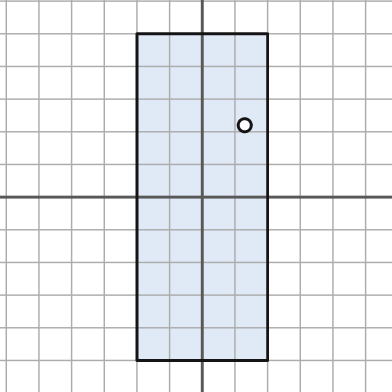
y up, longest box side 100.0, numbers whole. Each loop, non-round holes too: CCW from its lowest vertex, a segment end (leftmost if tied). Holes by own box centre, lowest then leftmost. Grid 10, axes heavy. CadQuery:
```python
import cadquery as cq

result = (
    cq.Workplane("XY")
    .moveTo(-20.0, -50.0)
    .lineTo(20.0, -50.0)
    .lineTo(20.0, 50.0)
    .lineTo(-20.0, 50.0)
    .close()
    .moveTo(13.0, 22.0)
    .circle(2.0)
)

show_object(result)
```